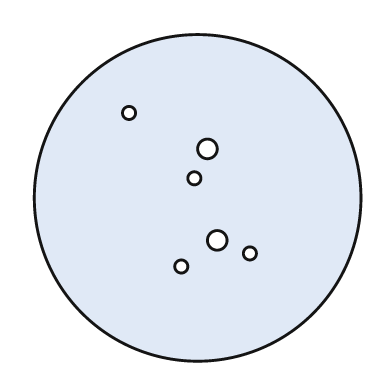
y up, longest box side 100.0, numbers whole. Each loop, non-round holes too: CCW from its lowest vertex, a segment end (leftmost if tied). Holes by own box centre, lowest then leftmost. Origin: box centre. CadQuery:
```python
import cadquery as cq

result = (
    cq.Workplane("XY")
    .moveTo(0.0, 0.0)
    .circle(50.0)
    .moveTo(-5.0, -21.0)
    .circle(2.0)
    .moveTo(16.0, -17.0)
    .circle(2.0)
    .moveTo(6.0, -13.0)
    .circle(3.0)
    .moveTo(-1.0, 6.0)
    .circle(2.0)
    .moveTo(3.0, 15.0)
    .circle(3.0)
    .moveTo(-21.0, 26.0)
    .circle(2.0)
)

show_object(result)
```